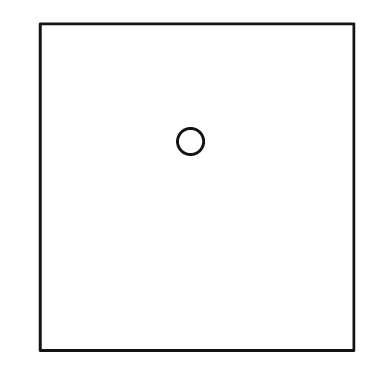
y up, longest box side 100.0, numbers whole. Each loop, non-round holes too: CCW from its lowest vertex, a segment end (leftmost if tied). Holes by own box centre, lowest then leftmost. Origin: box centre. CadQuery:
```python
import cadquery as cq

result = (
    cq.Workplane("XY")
    .moveTo(-48.0, -50.0)
    .lineTo(48.0, -50.0)
    .lineTo(48.0, 50.0)
    .lineTo(-48.0, 50.0)
    .close()
    .moveTo(-2.0, 14.0)
    .circle(4.0)
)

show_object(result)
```